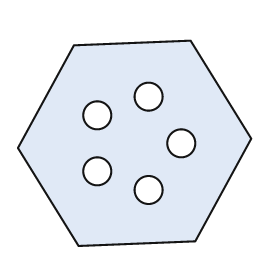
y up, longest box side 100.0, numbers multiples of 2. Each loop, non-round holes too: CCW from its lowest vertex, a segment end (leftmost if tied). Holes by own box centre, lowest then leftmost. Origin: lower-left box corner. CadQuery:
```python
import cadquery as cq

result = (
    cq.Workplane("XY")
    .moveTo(26.0, 0.0)
    .lineTo(76.0, 2.0)
    .lineTo(100.0, 46.0)
    .lineTo(74.0, 88.0)
    .lineTo(24.0, 86.0)
    .lineTo(0.0, 42.0)
    .close()
    .moveTo(56.0, 24.0)
    .circle(6.0)
    .moveTo(34.0, 32.0)
    .circle(6.0)
    .moveTo(70.0, 44.0)
    .circle(6.0)
    .moveTo(34.0, 56.0)
    .circle(6.0)
    .moveTo(56.0, 64.0)
    .circle(6.0)
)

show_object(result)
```